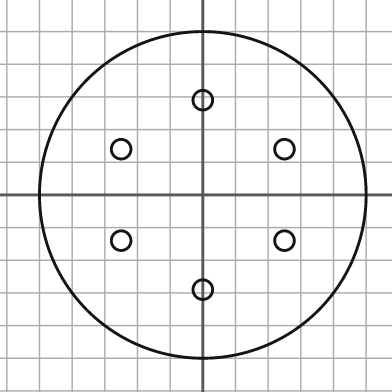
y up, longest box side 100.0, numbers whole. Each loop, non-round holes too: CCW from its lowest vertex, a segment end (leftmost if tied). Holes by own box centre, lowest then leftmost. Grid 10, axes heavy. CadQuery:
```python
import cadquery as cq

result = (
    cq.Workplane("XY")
    .moveTo(0.0, 0.0)
    .circle(50.0)
    .moveTo(0.0, -29.0)
    .circle(3.0)
    .moveTo(-25.0, -14.0)
    .circle(3.0)
    .moveTo(25.0, -14.0)
    .circle(3.0)
    .moveTo(-25.0, 14.0)
    .circle(3.0)
    .moveTo(25.0, 14.0)
    .circle(3.0)
    .moveTo(0.0, 29.0)
    .circle(3.0)
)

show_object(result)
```